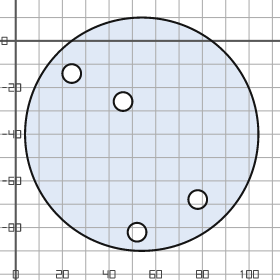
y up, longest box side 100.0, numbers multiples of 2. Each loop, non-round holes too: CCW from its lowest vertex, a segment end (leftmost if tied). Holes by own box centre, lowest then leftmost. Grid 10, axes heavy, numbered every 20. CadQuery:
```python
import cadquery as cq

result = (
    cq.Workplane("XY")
    .moveTo(54.0, -40.0)
    .circle(50.0)
    .moveTo(52.0, -82.0)
    .circle(4.0)
    .moveTo(78.0, -68.0)
    .circle(4.0)
    .moveTo(46.0, -26.0)
    .circle(4.0)
    .moveTo(24.0, -14.0)
    .circle(4.0)
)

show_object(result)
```